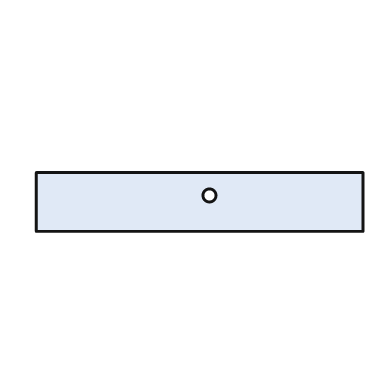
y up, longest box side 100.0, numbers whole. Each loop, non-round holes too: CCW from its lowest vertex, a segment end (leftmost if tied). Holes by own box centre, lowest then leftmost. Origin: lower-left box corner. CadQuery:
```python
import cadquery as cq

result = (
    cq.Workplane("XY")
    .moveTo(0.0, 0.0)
    .lineTo(100.0, 0.0)
    .lineTo(100.0, 18.0)
    .lineTo(0.0, 18.0)
    .close()
    .moveTo(53.0, 11.0)
    .circle(2.0)
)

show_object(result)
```